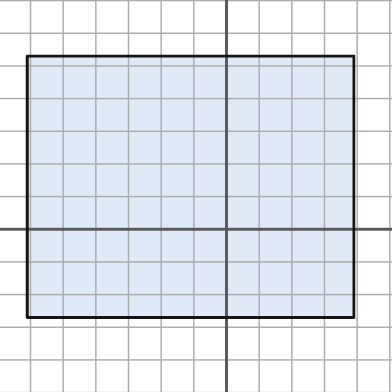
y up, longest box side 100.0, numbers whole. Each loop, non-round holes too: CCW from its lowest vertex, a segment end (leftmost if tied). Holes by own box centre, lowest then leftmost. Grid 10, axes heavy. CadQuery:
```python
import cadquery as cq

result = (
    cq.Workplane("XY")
    .moveTo(-61.0, -27.0)
    .lineTo(39.0, -27.0)
    .lineTo(39.0, 53.0)
    .lineTo(-61.0, 53.0)
    .close()
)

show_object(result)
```